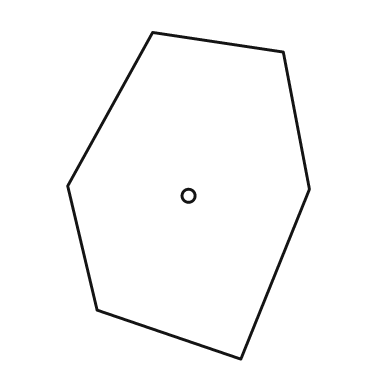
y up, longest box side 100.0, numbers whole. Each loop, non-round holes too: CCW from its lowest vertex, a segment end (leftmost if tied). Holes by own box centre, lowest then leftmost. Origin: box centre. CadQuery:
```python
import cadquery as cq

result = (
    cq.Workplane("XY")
    .moveTo(16.0, -50.0)
    .lineTo(37.0, 2.0)
    .lineTo(29.0, 44.0)
    .lineTo(-11.0, 50.0)
    .lineTo(-37.0, 3.0)
    .lineTo(-28.0, -35.0)
    .close()
    .moveTo(0.0, 0.0)
    .circle(2.0)
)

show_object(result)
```